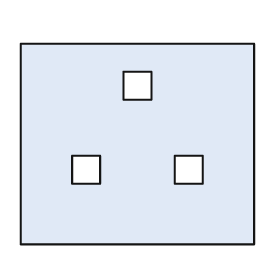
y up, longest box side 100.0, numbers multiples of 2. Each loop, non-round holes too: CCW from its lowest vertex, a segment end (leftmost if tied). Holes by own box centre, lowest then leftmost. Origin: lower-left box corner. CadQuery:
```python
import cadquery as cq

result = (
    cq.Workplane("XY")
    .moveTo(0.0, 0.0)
    .lineTo(100.0, 0.0)
    .lineTo(100.0, 86.0)
    .lineTo(0.0, 86.0)
    .close()
    .moveTo(22.0, 26.0)
    .lineTo(34.0, 26.0)
    .lineTo(34.0, 38.0)
    .lineTo(22.0, 38.0)
    .close()
    .moveTo(66.0, 26.0)
    .lineTo(78.0, 26.0)
    .lineTo(78.0, 38.0)
    .lineTo(66.0, 38.0)
    .close()
    .moveTo(44.0, 62.0)
    .lineTo(56.0, 62.0)
    .lineTo(56.0, 74.0)
    .lineTo(44.0, 74.0)
    .close()
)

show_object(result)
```